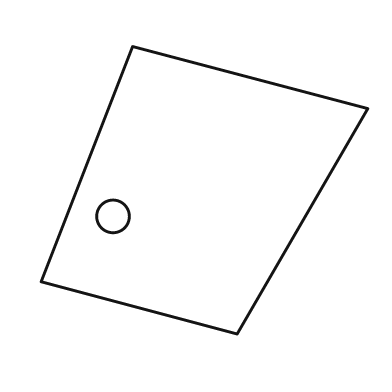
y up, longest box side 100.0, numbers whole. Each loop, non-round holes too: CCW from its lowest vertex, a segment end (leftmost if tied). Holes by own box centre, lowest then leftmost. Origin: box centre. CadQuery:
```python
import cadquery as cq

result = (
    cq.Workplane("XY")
    .moveTo(10.0, -44.0)
    .lineTo(50.0, 25.0)
    .lineTo(-22.0, 44.0)
    .lineTo(-50.0, -28.0)
    .close()
    .moveTo(-28.0, -8.0)
    .circle(5.0)
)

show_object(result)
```